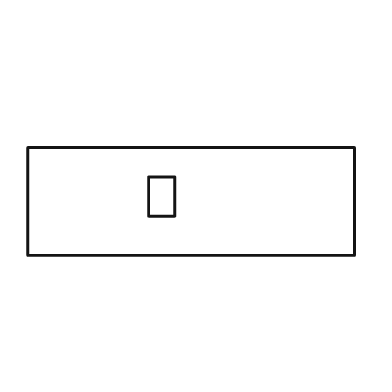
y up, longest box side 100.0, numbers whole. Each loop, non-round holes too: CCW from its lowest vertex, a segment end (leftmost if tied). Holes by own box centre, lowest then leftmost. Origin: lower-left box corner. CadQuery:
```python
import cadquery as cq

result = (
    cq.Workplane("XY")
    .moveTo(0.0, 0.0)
    .lineTo(100.0, 0.0)
    .lineTo(100.0, 33.0)
    .lineTo(0.0, 33.0)
    .close()
    .moveTo(37.0, 12.0)
    .lineTo(45.0, 12.0)
    .lineTo(45.0, 24.0)
    .lineTo(37.0, 24.0)
    .close()
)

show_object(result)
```